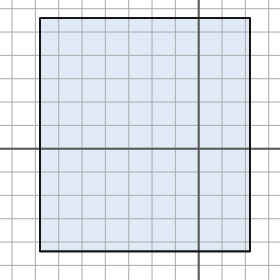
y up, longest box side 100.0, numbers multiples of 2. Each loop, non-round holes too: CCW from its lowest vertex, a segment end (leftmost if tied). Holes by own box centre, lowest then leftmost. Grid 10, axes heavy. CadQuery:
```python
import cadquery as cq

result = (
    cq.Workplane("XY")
    .moveTo(-68.0, -44.0)
    .lineTo(22.0, -44.0)
    .lineTo(22.0, 56.0)
    .lineTo(-68.0, 56.0)
    .close()
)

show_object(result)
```